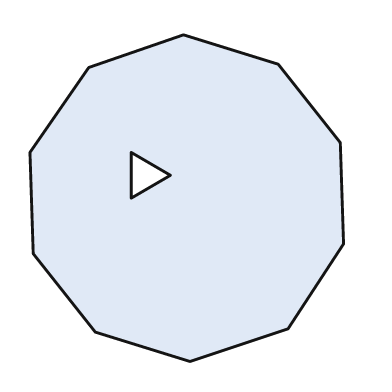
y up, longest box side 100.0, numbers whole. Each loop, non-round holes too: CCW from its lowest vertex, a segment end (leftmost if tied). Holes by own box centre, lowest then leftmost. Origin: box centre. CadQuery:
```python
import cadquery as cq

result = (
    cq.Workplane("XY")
    .moveTo(1.0, -50.0)
    .lineTo(31.0, -40.0)
    .lineTo(48.0, -14.0)
    .lineTo(47.0, 17.0)
    .lineTo(28.0, 41.0)
    .lineTo(-1.0, 50.0)
    .lineTo(-30.0, 40.0)
    .lineTo(-48.0, 14.0)
    .lineTo(-47.0, -17.0)
    .lineTo(-28.0, -41.0)
    .close()
    .moveTo(-17.0, 0.0)
    .lineTo(-5.0, 7.0)
    .lineTo(-17.0, 14.0)
    .close()
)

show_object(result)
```